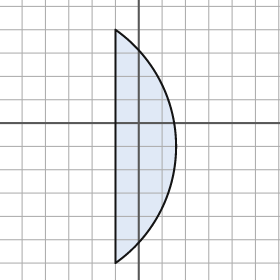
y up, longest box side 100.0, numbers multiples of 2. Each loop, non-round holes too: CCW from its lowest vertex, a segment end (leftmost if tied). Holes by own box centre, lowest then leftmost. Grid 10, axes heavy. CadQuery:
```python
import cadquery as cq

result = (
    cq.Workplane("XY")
    .moveTo(-10.0, -60.0)
    .threePointArc((16.0, -10.0), (-10.0, 40.0))
    .close()
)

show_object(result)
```